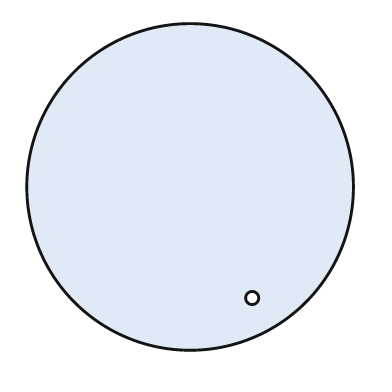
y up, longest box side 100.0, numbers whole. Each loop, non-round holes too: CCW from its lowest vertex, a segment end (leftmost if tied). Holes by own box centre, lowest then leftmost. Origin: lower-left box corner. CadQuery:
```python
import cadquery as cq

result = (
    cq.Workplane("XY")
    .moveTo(50.0, 50.0)
    .circle(50.0)
    .moveTo(69.0, 16.0)
    .circle(2.0)
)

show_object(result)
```